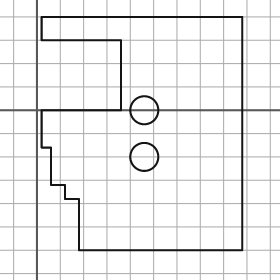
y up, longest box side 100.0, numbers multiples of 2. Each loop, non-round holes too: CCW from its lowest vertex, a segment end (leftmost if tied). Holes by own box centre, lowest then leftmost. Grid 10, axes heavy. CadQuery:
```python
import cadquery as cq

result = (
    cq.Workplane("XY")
    .moveTo(18.0, -60.0)
    .lineTo(88.0, -60.0)
    .lineTo(88.0, 40.0)
    .lineTo(2.0, 40.0)
    .lineTo(2.0, 30.0)
    .lineTo(36.0, 30.0)
    .lineTo(36.0, 0.0)
    .lineTo(2.0, 0.0)
    .lineTo(2.0, -16.0)
    .lineTo(6.0, -16.0)
    .lineTo(6.0, -32.0)
    .lineTo(12.0, -32.0)
    .lineTo(12.0, -38.0)
    .lineTo(18.0, -38.0)
    .close()
    .moveTo(46.0, -20.0)
    .circle(6.0)
    .moveTo(46.0, 0.0)
    .circle(6.0)
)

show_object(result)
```